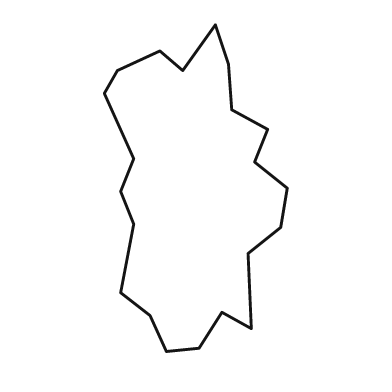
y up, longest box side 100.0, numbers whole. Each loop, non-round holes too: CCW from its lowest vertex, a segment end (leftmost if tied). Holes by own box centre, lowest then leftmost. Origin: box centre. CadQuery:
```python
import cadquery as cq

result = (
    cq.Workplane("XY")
    .moveTo(-9.0, -50.0)
    .lineTo(1.0, -49.0)
    .lineTo(8.0, -38.0)
    .lineTo(17.0, -43.0)
    .lineTo(16.0, -20.0)
    .lineTo(26.0, -12.0)
    .lineTo(28.0, 0.0)
    .lineTo(18.0, 8.0)
    .lineTo(22.0, 18.0)
    .lineTo(11.0, 24.0)
    .lineTo(10.0, 38.0)
    .lineTo(6.0, 50.0)
    .lineTo(-4.0, 36.0)
    .lineTo(-11.0, 42.0)
    .lineTo(-24.0, 36.0)
    .lineTo(-28.0, 29.0)
    .lineTo(-19.0, 9.0)
    .lineTo(-23.0, -1.0)
    .lineTo(-19.0, -11.0)
    .lineTo(-23.0, -32.0)
    .lineTo(-14.0, -39.0)
    .close()
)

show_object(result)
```